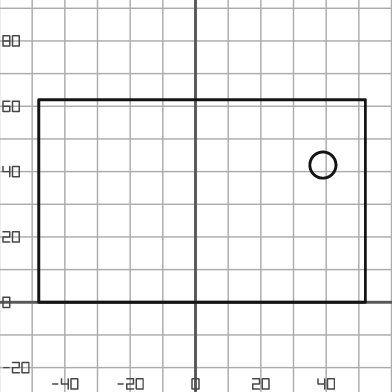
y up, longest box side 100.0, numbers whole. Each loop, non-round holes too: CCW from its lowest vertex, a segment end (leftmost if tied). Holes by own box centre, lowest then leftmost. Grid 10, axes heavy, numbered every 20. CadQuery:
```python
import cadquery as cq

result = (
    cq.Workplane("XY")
    .moveTo(-48.0, 0.0)
    .lineTo(52.0, 0.0)
    .lineTo(52.0, 62.0)
    .lineTo(-48.0, 62.0)
    .close()
    .moveTo(39.0, 42.0)
    .circle(4.0)
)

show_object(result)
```